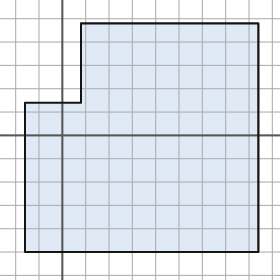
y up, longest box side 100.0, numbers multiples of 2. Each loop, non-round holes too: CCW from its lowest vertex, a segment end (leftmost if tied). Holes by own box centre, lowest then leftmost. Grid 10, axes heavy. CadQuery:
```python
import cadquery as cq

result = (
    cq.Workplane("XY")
    .moveTo(-16.0, -50.0)
    .lineTo(84.0, -50.0)
    .lineTo(84.0, 48.0)
    .lineTo(8.0, 48.0)
    .lineTo(8.0, 14.0)
    .lineTo(-16.0, 14.0)
    .close()
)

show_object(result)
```